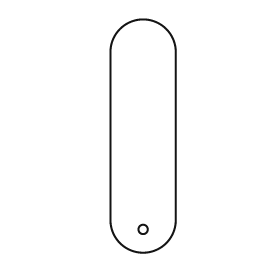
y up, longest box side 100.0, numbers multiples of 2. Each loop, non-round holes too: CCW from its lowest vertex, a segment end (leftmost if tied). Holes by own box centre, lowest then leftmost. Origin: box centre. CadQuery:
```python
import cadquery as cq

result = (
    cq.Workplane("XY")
    .moveTo(-14.0, -36.0)
    .threePointArc((0.0, -50.0), (14.0, -36.0))
    .lineTo(14.0, 36.0)
    .threePointArc((0.0, 50.0), (-14.0, 36.0))
    .close()
    .moveTo(0.0, -40.0)
    .circle(2.0)
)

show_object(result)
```